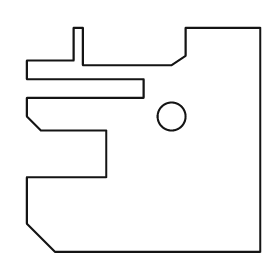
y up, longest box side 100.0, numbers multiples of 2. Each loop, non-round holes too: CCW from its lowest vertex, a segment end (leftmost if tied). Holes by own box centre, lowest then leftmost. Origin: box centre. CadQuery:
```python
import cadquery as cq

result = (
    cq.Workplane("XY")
    .moveTo(-38.0, -48.0)
    .lineTo(50.0, -48.0)
    .lineTo(50.0, 48.0)
    .lineTo(18.0, 48.0)
    .lineTo(18.0, 36.0)
    .lineTo(12.0, 32.0)
    .lineTo(-26.0, 32.0)
    .lineTo(-26.0, 48.0)
    .lineTo(-30.0, 48.0)
    .lineTo(-30.0, 34.0)
    .lineTo(-50.0, 34.0)
    .lineTo(-50.0, 26.0)
    .lineTo(0.0, 26.0)
    .lineTo(0.0, 18.0)
    .lineTo(-50.0, 18.0)
    .lineTo(-50.0, 10.0)
    .lineTo(-44.0, 4.0)
    .lineTo(-16.0, 4.0)
    .lineTo(-16.0, -16.0)
    .lineTo(-50.0, -16.0)
    .lineTo(-50.0, -36.0)
    .close()
    .moveTo(12.0, 10.0)
    .circle(6.0)
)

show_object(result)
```